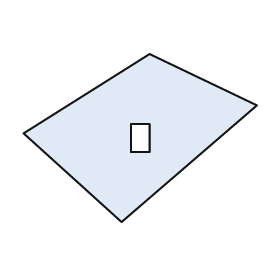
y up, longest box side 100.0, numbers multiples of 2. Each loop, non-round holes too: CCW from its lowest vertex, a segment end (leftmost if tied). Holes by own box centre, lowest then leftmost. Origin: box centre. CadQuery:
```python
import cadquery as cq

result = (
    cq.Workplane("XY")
    .moveTo(-8.0, -36.0)
    .lineTo(50.0, 14.0)
    .lineTo(4.0, 36.0)
    .lineTo(-50.0, 2.0)
    .close()
    .moveTo(-4.0, -6.0)
    .lineTo(4.0, -6.0)
    .lineTo(4.0, 6.0)
    .lineTo(-4.0, 6.0)
    .close()
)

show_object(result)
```